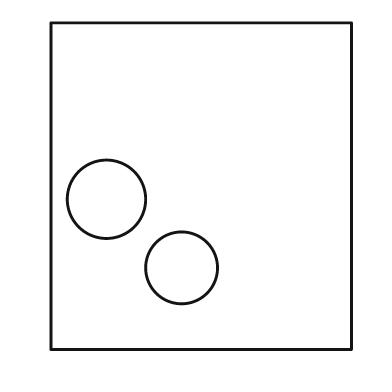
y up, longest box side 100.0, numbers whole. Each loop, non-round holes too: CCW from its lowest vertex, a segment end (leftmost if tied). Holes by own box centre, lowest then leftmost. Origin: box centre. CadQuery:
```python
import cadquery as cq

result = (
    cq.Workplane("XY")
    .moveTo(-46.0, -50.0)
    .lineTo(46.0, -50.0)
    .lineTo(46.0, 50.0)
    .lineTo(-46.0, 50.0)
    .close()
    .moveTo(-6.0, -25.0)
    .circle(11.0)
    .moveTo(-29.0, -4.0)
    .circle(12.0)
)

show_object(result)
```